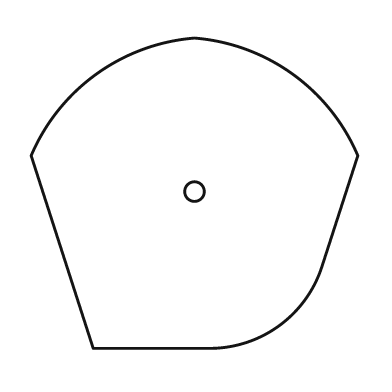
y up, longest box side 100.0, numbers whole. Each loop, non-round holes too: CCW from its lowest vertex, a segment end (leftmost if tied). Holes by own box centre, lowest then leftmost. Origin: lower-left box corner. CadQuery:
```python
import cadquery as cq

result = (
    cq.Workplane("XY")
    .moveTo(19.0, 0.0)
    .lineTo(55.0, 0.0)
    .threePointArc((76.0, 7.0), (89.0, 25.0))
    .lineTo(100.0, 59.0)
    .threePointArc((80.0, 84.0), (50.0, 95.0))
    .threePointArc((20.0, 84.0), (0.0, 59.0))
    .close()
    .moveTo(50.0, 48.0)
    .circle(3.0)
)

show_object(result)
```